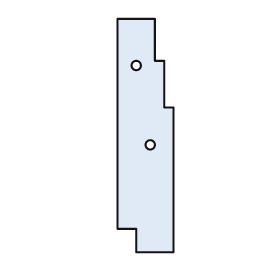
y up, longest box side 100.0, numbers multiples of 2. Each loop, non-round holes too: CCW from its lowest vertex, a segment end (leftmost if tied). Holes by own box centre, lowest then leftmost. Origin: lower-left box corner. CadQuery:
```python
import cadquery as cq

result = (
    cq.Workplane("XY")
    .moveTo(8.0, 0.0)
    .lineTo(24.0, 0.0)
    .lineTo(24.0, 62.0)
    .lineTo(20.0, 62.0)
    .lineTo(20.0, 82.0)
    .lineTo(16.0, 82.0)
    .lineTo(16.0, 100.0)
    .lineTo(0.0, 100.0)
    .lineTo(0.0, 10.0)
    .lineTo(8.0, 10.0)
    .close()
    .moveTo(14.0, 46.0)
    .circle(2.0)
    .moveTo(8.0, 80.0)
    .circle(2.0)
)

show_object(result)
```